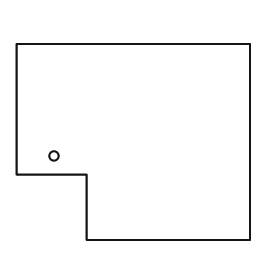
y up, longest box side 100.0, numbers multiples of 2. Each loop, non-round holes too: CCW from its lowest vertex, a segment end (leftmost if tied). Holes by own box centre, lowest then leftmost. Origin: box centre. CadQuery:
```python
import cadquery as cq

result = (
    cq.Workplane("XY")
    .moveTo(-20.0, -42.0)
    .lineTo(50.0, -42.0)
    .lineTo(50.0, 42.0)
    .lineTo(-50.0, 42.0)
    .lineTo(-50.0, -14.0)
    .lineTo(-20.0, -14.0)
    .close()
    .moveTo(-34.0, -6.0)
    .circle(2.0)
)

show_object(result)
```